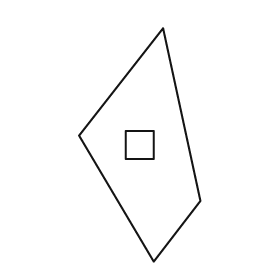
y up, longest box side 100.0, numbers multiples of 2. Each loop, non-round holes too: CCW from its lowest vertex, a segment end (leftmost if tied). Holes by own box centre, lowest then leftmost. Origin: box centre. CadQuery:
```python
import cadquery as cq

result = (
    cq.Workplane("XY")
    .moveTo(6.0, -50.0)
    .lineTo(26.0, -24.0)
    .lineTo(10.0, 50.0)
    .lineTo(-26.0, 4.0)
    .close()
    .moveTo(-6.0, -6.0)
    .lineTo(6.0, -6.0)
    .lineTo(6.0, 6.0)
    .lineTo(-6.0, 6.0)
    .close()
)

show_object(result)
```